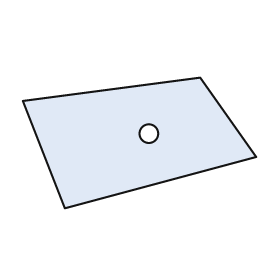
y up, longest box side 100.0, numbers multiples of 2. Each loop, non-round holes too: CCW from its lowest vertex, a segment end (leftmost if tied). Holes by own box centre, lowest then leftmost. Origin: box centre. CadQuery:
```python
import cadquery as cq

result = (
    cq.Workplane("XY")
    .moveTo(-32.0, -28.0)
    .lineTo(50.0, -6.0)
    .lineTo(26.0, 28.0)
    .lineTo(-50.0, 18.0)
    .close()
    .moveTo(4.0, 4.0)
    .circle(4.0)
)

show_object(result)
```